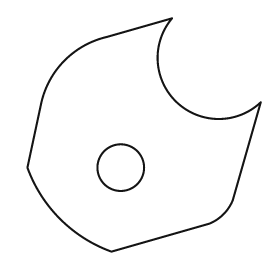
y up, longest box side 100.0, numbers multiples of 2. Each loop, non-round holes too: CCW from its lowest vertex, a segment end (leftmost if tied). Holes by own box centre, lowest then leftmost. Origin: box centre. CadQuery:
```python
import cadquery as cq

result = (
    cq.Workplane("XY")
    .moveTo(-14.0, -50.0)
    .lineTo(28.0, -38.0)
    .threePointArc((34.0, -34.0), (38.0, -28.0))
    .lineTo(50.0, 14.0)
    .threePointArc((14.0, 14.0), (12.0, 50.0))
    .lineTo(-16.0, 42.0)
    .threePointArc((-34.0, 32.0), (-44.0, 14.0))
    .lineTo(-50.0, -14.0)
    .threePointArc((-36.0, -36.0), (-14.0, -50.0))
    .close()
    .moveTo(-10.0, -14.0)
    .circle(10.0)
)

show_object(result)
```